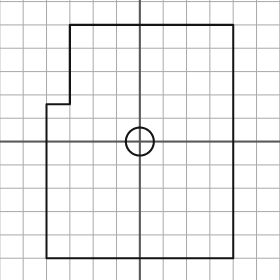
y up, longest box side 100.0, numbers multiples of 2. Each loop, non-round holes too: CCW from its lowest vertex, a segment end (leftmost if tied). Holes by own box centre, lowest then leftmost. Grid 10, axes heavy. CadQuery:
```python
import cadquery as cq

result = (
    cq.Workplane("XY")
    .moveTo(-40.0, -50.0)
    .lineTo(40.0, -50.0)
    .lineTo(40.0, 50.0)
    .lineTo(-30.0, 50.0)
    .lineTo(-30.0, 16.0)
    .lineTo(-40.0, 16.0)
    .close()
    .moveTo(0.0, 0.0)
    .circle(6.0)
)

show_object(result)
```